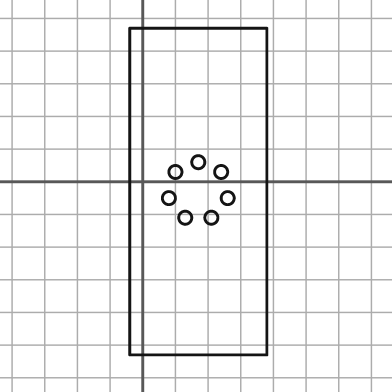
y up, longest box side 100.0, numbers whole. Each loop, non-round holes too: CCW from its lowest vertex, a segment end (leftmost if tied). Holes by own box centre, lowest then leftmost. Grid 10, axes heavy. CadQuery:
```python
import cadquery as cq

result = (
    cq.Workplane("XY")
    .moveTo(-4.0, -53.0)
    .lineTo(38.0, -53.0)
    .lineTo(38.0, 47.0)
    .lineTo(-4.0, 47.0)
    .close()
    .moveTo(13.0, -11.0)
    .circle(2.0)
    .moveTo(21.0, -11.0)
    .circle(2.0)
    .moveTo(8.0, -5.0)
    .circle(2.0)
    .moveTo(26.0, -5.0)
    .circle(2.0)
    .moveTo(10.0, 3.0)
    .circle(2.0)
    .moveTo(24.0, 3.0)
    .circle(2.0)
    .moveTo(17.0, 6.0)
    .circle(2.0)
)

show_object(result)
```